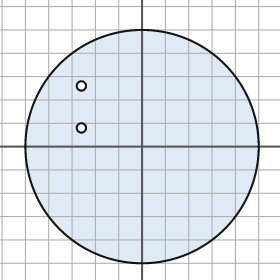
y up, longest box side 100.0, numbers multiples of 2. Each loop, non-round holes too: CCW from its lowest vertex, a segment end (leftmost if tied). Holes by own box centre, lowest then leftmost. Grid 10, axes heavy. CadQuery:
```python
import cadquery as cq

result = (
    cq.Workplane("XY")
    .moveTo(0.0, 0.0)
    .circle(50.0)
    .moveTo(-26.0, 8.0)
    .circle(2.0)
    .moveTo(-26.0, 26.0)
    .circle(2.0)
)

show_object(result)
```